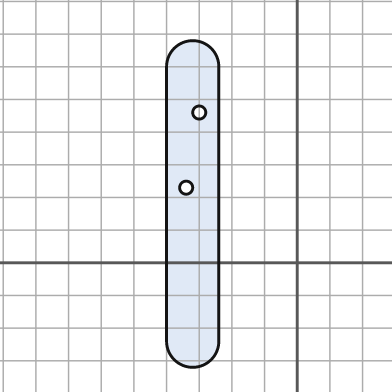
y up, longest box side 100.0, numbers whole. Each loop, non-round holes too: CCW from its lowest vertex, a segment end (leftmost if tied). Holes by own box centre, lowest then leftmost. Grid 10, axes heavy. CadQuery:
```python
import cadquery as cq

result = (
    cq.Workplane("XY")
    .moveTo(-40.0, -24.0)
    .threePointArc((-32.0, -32.0), (-24.0, -24.0))
    .lineTo(-24.0, 60.0)
    .threePointArc((-32.0, 68.0), (-40.0, 60.0))
    .close()
    .moveTo(-34.0, 23.0)
    .circle(2.0)
    .moveTo(-30.0, 46.0)
    .circle(2.0)
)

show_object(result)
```